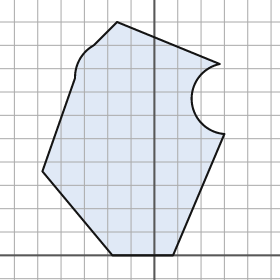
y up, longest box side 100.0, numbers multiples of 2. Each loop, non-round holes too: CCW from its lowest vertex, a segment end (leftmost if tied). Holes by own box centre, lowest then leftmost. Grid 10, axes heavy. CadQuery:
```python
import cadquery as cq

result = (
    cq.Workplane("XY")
    .moveTo(-18.0, 0.0)
    .lineTo(8.0, 0.0)
    .lineTo(30.0, 52.0)
    .threePointArc((16.0, 66.0), (28.0, 82.0))
    .lineTo(-16.0, 100.0)
    .lineTo(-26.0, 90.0)
    .threePointArc((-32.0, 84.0), (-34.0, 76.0))
    .lineTo(-48.0, 36.0)
    .close()
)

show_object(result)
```